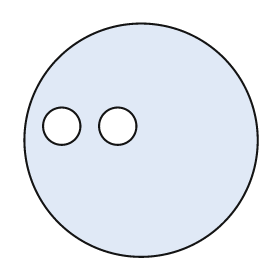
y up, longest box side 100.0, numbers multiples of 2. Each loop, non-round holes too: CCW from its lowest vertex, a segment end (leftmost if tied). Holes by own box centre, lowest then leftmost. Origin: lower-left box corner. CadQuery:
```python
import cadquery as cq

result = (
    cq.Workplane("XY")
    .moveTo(50.0, 50.0)
    .circle(50.0)
    .moveTo(16.0, 56.0)
    .circle(8.0)
    .moveTo(40.0, 56.0)
    .circle(8.0)
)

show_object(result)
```